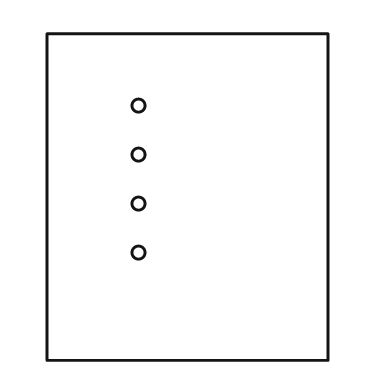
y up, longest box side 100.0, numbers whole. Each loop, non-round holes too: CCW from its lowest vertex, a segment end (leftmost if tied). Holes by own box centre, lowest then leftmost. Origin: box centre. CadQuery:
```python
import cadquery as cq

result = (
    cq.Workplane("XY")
    .moveTo(-43.0, -50.0)
    .lineTo(43.0, -50.0)
    .lineTo(43.0, 50.0)
    .lineTo(-43.0, 50.0)
    .close()
    .moveTo(-15.0, -17.0)
    .circle(2.0)
    .moveTo(-15.0, -2.0)
    .circle(2.0)
    .moveTo(-15.0, 13.0)
    .circle(2.0)
    .moveTo(-15.0, 28.0)
    .circle(2.0)
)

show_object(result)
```